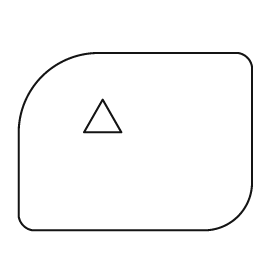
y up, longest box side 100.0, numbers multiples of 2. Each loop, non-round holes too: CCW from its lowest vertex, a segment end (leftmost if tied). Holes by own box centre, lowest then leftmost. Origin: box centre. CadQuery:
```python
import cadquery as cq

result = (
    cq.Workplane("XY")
    .moveTo(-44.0, -38.0)
    .lineTo(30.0, -38.0)
    .threePointArc((44.0, -32.0), (50.0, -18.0))
    .lineTo(50.0, 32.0)
    .threePointArc((48.0, 36.0), (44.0, 38.0))
    .lineTo(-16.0, 38.0)
    .threePointArc((-40.0, 28.0), (-50.0, 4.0))
    .lineTo(-50.0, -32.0)
    .threePointArc((-48.0, -36.0), (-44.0, -38.0))
    .close()
    .moveTo(-22.0, 4.0)
    .lineTo(-6.0, 4.0)
    .lineTo(-14.0, 18.0)
    .close()
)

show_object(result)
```